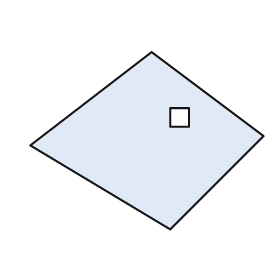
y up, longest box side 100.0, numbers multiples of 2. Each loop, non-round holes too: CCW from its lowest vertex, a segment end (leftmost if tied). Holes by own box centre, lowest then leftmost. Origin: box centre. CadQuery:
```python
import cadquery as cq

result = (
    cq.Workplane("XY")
    .moveTo(10.0, -38.0)
    .lineTo(50.0, 2.0)
    .lineTo(2.0, 38.0)
    .lineTo(-50.0, -2.0)
    .close()
    .moveTo(10.0, 6.0)
    .lineTo(18.0, 6.0)
    .lineTo(18.0, 14.0)
    .lineTo(10.0, 14.0)
    .close()
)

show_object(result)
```